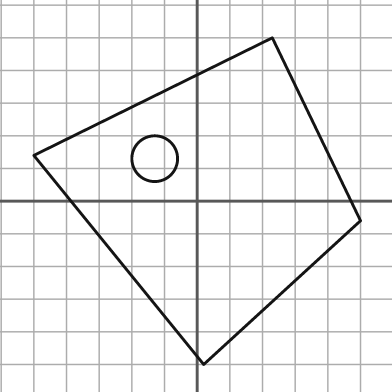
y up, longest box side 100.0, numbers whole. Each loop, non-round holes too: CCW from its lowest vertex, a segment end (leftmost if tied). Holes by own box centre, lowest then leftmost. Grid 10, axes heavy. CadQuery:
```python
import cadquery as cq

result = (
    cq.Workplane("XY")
    .moveTo(2.0, -50.0)
    .lineTo(50.0, -6.0)
    .lineTo(23.0, 50.0)
    .lineTo(-50.0, 14.0)
    .close()
    .moveTo(-13.0, 13.0)
    .circle(7.0)
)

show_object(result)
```